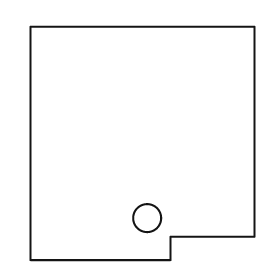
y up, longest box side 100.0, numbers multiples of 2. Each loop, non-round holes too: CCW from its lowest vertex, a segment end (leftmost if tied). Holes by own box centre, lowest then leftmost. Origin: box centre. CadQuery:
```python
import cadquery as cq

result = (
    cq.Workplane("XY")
    .moveTo(-48.0, -50.0)
    .lineTo(12.0, -50.0)
    .lineTo(12.0, -40.0)
    .lineTo(48.0, -40.0)
    .lineTo(48.0, 50.0)
    .lineTo(-48.0, 50.0)
    .close()
    .moveTo(2.0, -32.0)
    .circle(6.0)
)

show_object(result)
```